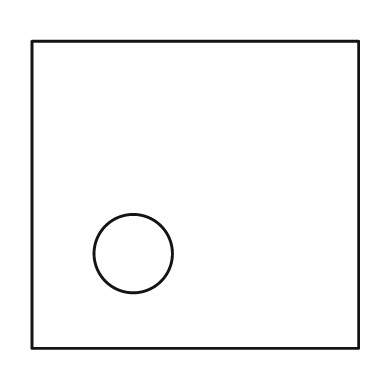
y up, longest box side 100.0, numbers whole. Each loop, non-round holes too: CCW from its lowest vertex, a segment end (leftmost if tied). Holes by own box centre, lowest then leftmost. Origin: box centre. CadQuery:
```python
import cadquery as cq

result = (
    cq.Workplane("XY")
    .moveTo(-50.0, -47.0)
    .lineTo(50.0, -47.0)
    .lineTo(50.0, 47.0)
    .lineTo(-50.0, 47.0)
    .close()
    .moveTo(-19.0, -18.0)
    .circle(12.0)
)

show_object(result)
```